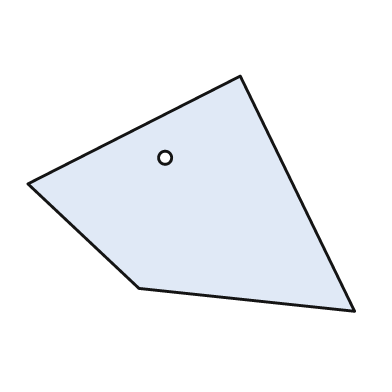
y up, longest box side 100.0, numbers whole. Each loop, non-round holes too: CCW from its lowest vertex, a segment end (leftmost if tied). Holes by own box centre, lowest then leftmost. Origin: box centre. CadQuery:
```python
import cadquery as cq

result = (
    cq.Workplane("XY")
    .moveTo(50.0, -36.0)
    .lineTo(15.0, 36.0)
    .lineTo(-50.0, 3.0)
    .lineTo(-16.0, -29.0)
    .close()
    .moveTo(-8.0, 11.0)
    .circle(2.0)
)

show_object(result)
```